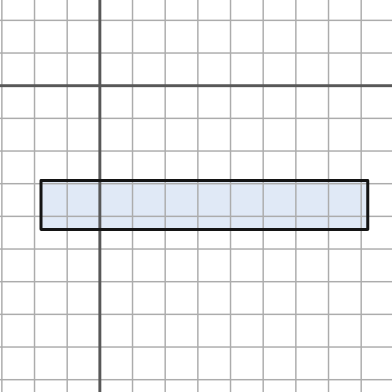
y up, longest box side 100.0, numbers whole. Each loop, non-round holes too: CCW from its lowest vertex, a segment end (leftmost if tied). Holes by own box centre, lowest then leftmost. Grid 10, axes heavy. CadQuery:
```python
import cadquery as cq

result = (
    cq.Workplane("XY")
    .moveTo(-18.0, -44.0)
    .lineTo(82.0, -44.0)
    .lineTo(82.0, -29.0)
    .lineTo(-18.0, -29.0)
    .close()
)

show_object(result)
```